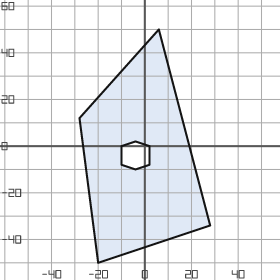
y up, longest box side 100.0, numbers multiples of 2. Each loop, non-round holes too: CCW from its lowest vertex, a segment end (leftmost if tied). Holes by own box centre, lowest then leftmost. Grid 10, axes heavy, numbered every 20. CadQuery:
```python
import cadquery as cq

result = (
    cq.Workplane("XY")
    .moveTo(-20.0, -50.0)
    .lineTo(28.0, -34.0)
    .lineTo(6.0, 50.0)
    .lineTo(-28.0, 12.0)
    .close()
    .moveTo(-4.0, -10.0)
    .lineTo(2.0, -8.0)
    .lineTo(2.0, 0.0)
    .lineTo(-4.0, 2.0)
    .lineTo(-10.0, 0.0)
    .lineTo(-10.0, -8.0)
    .close()
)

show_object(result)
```